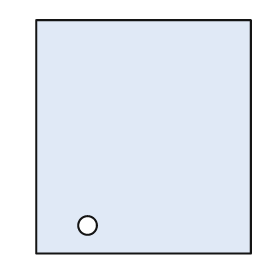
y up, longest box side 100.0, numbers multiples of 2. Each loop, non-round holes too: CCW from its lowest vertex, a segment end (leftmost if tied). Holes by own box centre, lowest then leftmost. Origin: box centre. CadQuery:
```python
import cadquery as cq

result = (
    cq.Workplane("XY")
    .moveTo(-46.0, -50.0)
    .lineTo(46.0, -50.0)
    .lineTo(46.0, 50.0)
    .lineTo(-46.0, 50.0)
    .close()
    .moveTo(-24.0, -38.0)
    .circle(4.0)
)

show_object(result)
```